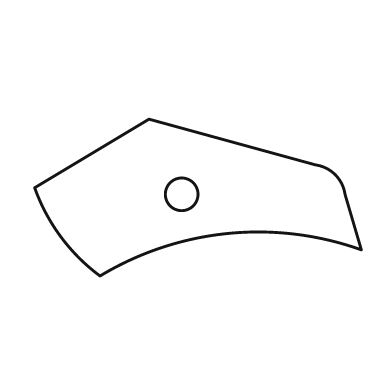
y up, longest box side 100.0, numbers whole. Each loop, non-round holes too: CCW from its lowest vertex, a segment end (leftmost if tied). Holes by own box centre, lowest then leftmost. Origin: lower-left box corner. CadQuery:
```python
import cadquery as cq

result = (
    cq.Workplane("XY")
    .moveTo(20.0, 0.0)
    .threePointArc((59.0, 13.0), (100.0, 8.0))
    .lineTo(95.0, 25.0)
    .threePointArc((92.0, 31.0), (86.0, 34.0))
    .lineTo(35.0, 48.0)
    .lineTo(0.0, 27.0)
    .threePointArc((8.0, 12.0), (20.0, 0.0))
    .close()
    .moveTo(45.0, 25.0)
    .circle(5.0)
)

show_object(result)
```